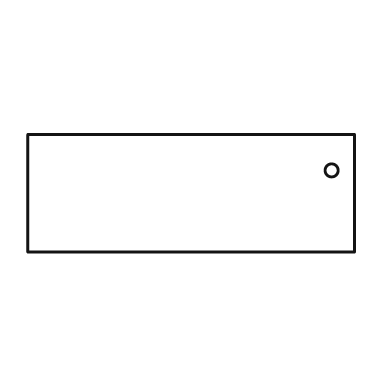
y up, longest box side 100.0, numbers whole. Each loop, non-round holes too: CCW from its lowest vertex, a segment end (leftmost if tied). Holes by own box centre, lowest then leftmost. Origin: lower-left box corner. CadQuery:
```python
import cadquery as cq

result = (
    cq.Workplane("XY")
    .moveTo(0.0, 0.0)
    .lineTo(100.0, 0.0)
    .lineTo(100.0, 36.0)
    .lineTo(0.0, 36.0)
    .close()
    .moveTo(93.0, 25.0)
    .circle(2.0)
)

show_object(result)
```